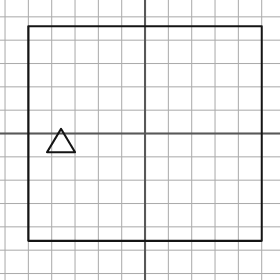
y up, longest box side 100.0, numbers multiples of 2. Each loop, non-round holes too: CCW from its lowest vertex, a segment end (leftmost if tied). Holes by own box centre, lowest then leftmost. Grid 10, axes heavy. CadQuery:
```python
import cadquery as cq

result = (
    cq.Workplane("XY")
    .moveTo(-50.0, -46.0)
    .lineTo(50.0, -46.0)
    .lineTo(50.0, 46.0)
    .lineTo(-50.0, 46.0)
    .close()
    .moveTo(-42.0, -8.0)
    .lineTo(-30.0, -8.0)
    .lineTo(-36.0, 2.0)
    .close()
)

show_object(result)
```